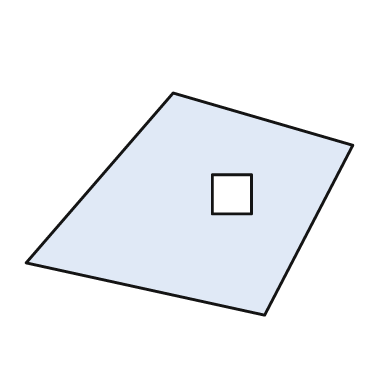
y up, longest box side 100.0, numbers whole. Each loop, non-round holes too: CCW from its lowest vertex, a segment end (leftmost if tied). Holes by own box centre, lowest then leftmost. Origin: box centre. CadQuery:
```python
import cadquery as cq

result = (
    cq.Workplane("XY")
    .moveTo(23.0, -34.0)
    .lineTo(50.0, 18.0)
    .lineTo(-5.0, 34.0)
    .lineTo(-50.0, -18.0)
    .close()
    .moveTo(7.0, -3.0)
    .lineTo(19.0, -3.0)
    .lineTo(19.0, 9.0)
    .lineTo(7.0, 9.0)
    .close()
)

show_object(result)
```